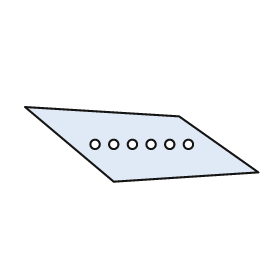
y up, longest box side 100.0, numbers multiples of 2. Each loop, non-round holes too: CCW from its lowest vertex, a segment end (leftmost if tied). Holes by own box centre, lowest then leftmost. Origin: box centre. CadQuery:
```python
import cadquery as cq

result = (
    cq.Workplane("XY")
    .moveTo(-12.0, -16.0)
    .lineTo(50.0, -12.0)
    .lineTo(16.0, 12.0)
    .lineTo(-50.0, 16.0)
    .close()
    .moveTo(-20.0, 0.0)
    .circle(2.0)
    .moveTo(-12.0, 0.0)
    .circle(2.0)
    .moveTo(-4.0, 0.0)
    .circle(2.0)
    .moveTo(4.0, 0.0)
    .circle(2.0)
    .moveTo(12.0, 0.0)
    .circle(2.0)
    .moveTo(20.0, 0.0)
    .circle(2.0)
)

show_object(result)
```